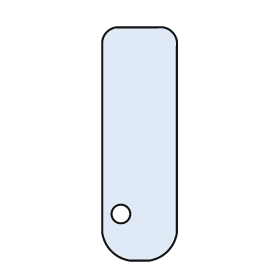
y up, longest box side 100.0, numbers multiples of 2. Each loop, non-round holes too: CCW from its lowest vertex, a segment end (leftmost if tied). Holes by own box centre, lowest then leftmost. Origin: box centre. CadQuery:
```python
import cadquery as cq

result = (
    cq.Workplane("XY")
    .moveTo(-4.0, -50.0)
    .lineTo(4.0, -50.0)
    .threePointArc((12.0, -46.0), (16.0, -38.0))
    .lineTo(16.0, 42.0)
    .threePointArc((14.0, 48.0), (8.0, 50.0))
    .lineTo(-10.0, 50.0)
    .threePointArc((-14.0, 48.0), (-16.0, 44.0))
    .lineTo(-16.0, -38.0)
    .threePointArc((-12.0, -46.0), (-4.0, -50.0))
    .close()
    .moveTo(-8.0, -30.0)
    .circle(4.0)
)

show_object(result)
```